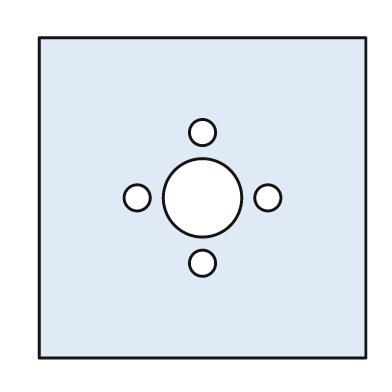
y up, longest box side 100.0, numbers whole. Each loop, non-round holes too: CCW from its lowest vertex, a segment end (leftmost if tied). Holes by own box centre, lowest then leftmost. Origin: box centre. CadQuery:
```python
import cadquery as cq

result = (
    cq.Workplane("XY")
    .moveTo(-50.0, -49.0)
    .lineTo(50.0, -49.0)
    .lineTo(50.0, 49.0)
    .lineTo(-50.0, 49.0)
    .close()
    .moveTo(0.0, -20.0)
    .circle(4.0)
    .moveTo(-20.0, 0.0)
    .circle(4.0)
    .moveTo(0.0, 0.0)
    .circle(12.0)
    .moveTo(20.0, 0.0)
    .circle(4.0)
    .moveTo(0.0, 20.0)
    .circle(4.0)
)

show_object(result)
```